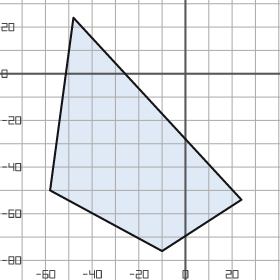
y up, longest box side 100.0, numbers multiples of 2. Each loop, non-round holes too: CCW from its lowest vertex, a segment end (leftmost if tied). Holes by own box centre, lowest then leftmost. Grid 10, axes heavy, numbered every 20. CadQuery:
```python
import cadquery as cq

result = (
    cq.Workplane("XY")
    .moveTo(-10.0, -76.0)
    .lineTo(24.0, -54.0)
    .lineTo(-48.0, 24.0)
    .lineTo(-58.0, -50.0)
    .close()
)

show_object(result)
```